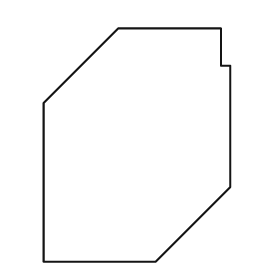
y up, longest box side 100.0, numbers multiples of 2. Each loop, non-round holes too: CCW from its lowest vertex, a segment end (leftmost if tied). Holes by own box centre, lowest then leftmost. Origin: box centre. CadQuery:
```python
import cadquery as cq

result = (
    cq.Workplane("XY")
    .moveTo(-40.0, -50.0)
    .lineTo(8.0, -50.0)
    .lineTo(40.0, -18.0)
    .lineTo(40.0, 34.0)
    .lineTo(36.0, 34.0)
    .lineTo(36.0, 50.0)
    .lineTo(-8.0, 50.0)
    .lineTo(-40.0, 18.0)
    .close()
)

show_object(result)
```